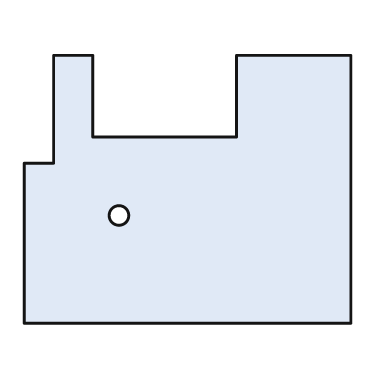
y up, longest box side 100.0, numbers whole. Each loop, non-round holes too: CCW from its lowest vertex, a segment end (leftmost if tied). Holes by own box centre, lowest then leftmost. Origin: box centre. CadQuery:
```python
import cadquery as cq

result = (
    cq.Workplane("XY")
    .moveTo(-50.0, -41.0)
    .lineTo(50.0, -41.0)
    .lineTo(50.0, 41.0)
    .lineTo(15.0, 41.0)
    .lineTo(15.0, 16.0)
    .lineTo(-29.0, 16.0)
    .lineTo(-29.0, 41.0)
    .lineTo(-41.0, 41.0)
    .lineTo(-41.0, 8.0)
    .lineTo(-50.0, 8.0)
    .close()
    .moveTo(-21.0, -8.0)
    .circle(3.0)
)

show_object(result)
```